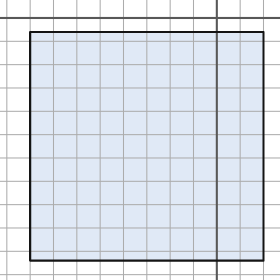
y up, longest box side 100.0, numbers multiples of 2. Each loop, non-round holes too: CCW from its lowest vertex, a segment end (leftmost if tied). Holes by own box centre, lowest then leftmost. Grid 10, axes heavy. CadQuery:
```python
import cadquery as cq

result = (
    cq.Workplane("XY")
    .moveTo(-80.0, -104.0)
    .lineTo(20.0, -104.0)
    .lineTo(20.0, -6.0)
    .lineTo(-80.0, -6.0)
    .close()
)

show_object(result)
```